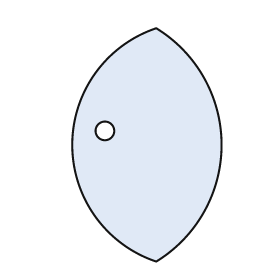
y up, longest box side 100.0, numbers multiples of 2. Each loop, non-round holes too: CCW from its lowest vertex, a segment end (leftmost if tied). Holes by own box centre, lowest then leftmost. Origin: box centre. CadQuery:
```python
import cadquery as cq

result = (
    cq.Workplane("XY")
    .moveTo(4.0, -50.0)
    .threePointArc((32.0, 0.0), (4.0, 50.0))
    .threePointArc((-32.0, 0.0), (4.0, -50.0))
    .close()
    .moveTo(-18.0, 6.0)
    .circle(4.0)
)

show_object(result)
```